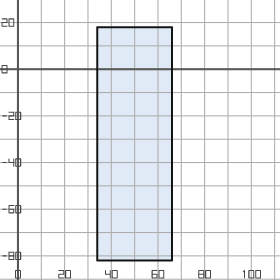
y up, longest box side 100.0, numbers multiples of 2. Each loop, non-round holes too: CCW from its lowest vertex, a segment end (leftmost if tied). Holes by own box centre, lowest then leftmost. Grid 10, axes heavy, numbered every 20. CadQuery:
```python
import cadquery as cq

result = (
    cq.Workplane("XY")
    .moveTo(34.0, -82.0)
    .lineTo(66.0, -82.0)
    .lineTo(66.0, 18.0)
    .lineTo(34.0, 18.0)
    .close()
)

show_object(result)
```